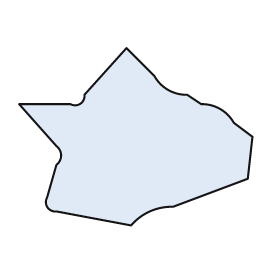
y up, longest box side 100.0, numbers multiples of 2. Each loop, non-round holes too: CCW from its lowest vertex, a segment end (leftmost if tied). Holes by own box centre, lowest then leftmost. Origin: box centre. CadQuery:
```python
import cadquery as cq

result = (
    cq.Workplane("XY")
    .moveTo(-2.0, -38.0)
    .threePointArc((6.0, -32.0), (16.0, -30.0))
    .lineTo(48.0, -18.0)
    .lineTo(50.0, 0.0)
    .lineTo(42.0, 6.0)
    .threePointArc((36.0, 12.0), (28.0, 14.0))
    .lineTo(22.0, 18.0)
    .threePointArc((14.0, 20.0), (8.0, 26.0))
    .lineTo(-4.0, 38.0)
    .lineTo(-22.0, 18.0)
    .threePointArc((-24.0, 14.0), (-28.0, 14.0))
    .lineTo(-50.0, 14.0)
    .lineTo(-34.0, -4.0)
    .threePointArc((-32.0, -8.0), (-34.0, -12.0))
    .lineTo(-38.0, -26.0)
    .threePointArc((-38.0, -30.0), (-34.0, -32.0))
    .close()
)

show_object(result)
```